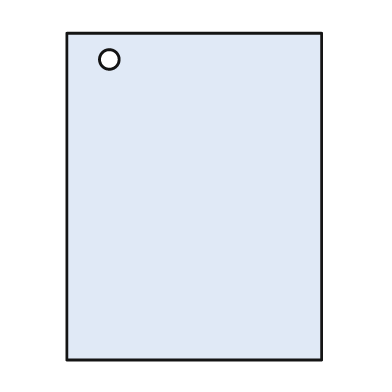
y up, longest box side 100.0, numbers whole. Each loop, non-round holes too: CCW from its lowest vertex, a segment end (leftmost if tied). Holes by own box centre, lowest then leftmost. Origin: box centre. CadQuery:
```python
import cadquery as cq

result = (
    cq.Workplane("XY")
    .moveTo(-39.0, -50.0)
    .lineTo(39.0, -50.0)
    .lineTo(39.0, 50.0)
    .lineTo(-39.0, 50.0)
    .close()
    .moveTo(-26.0, 42.0)
    .circle(3.0)
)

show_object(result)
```